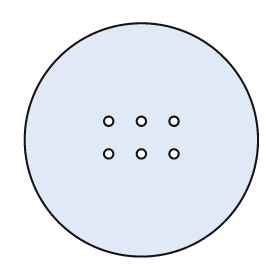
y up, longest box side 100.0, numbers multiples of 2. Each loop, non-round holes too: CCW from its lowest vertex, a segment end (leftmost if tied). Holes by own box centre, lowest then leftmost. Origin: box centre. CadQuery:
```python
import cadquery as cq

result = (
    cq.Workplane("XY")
    .moveTo(0.0, 0.0)
    .circle(50.0)
    .moveTo(-14.0, -6.0)
    .circle(2.0)
    .moveTo(0.0, -6.0)
    .circle(2.0)
    .moveTo(14.0, -6.0)
    .circle(2.0)
    .moveTo(-14.0, 8.0)
    .circle(2.0)
    .moveTo(0.0, 8.0)
    .circle(2.0)
    .moveTo(14.0, 8.0)
    .circle(2.0)
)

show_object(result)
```